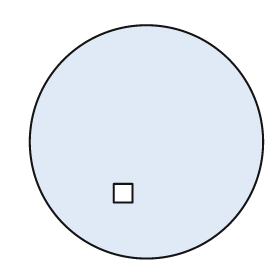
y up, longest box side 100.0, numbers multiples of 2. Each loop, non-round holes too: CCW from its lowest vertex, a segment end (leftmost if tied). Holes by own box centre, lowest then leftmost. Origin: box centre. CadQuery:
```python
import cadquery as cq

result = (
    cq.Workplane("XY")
    .moveTo(0.0, 0.0)
    .circle(50.0)
    .moveTo(-14.0, -26.0)
    .lineTo(-6.0, -26.0)
    .lineTo(-6.0, -18.0)
    .lineTo(-14.0, -18.0)
    .close()
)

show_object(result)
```